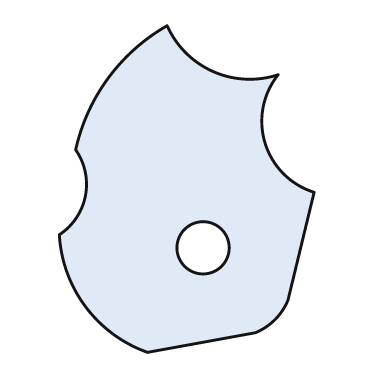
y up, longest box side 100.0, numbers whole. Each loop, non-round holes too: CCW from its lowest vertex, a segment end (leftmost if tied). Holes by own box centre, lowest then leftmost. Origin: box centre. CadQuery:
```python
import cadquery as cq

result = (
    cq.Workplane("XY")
    .moveTo(-12.0, -50.0)
    .lineTo(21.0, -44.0)
    .threePointArc((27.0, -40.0), (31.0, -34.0))
    .lineTo(39.0, -1.0)
    .threePointArc((24.0, 14.0), (28.0, 35.0))
    .threePointArc((8.0, 36.0), (-6.0, 50.0))
    .threePointArc((-24.0, 34.0), (-34.0, 12.0))
    .threePointArc((-31.0, -2.0), (-39.0, -14.0))
    .threePointArc((-31.0, -36.0), (-12.0, -50.0))
    .close()
    .moveTo(5.0, -18.0)
    .circle(8.0)
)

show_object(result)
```